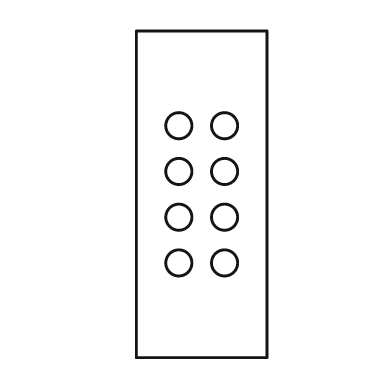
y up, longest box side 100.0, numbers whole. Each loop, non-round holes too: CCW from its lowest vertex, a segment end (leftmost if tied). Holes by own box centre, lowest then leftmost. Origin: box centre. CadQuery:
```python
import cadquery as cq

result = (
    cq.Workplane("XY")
    .moveTo(-20.0, -50.0)
    .lineTo(20.0, -50.0)
    .lineTo(20.0, 50.0)
    .lineTo(-20.0, 50.0)
    .close()
    .moveTo(-7.0, -21.0)
    .circle(4.0)
    .moveTo(7.0, -21.0)
    .circle(4.0)
    .moveTo(-7.0, -7.0)
    .circle(4.0)
    .moveTo(7.0, -7.0)
    .circle(4.0)
    .moveTo(-7.0, 7.0)
    .circle(4.0)
    .moveTo(7.0, 7.0)
    .circle(4.0)
    .moveTo(-7.0, 21.0)
    .circle(4.0)
    .moveTo(7.0, 21.0)
    .circle(4.0)
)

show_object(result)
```